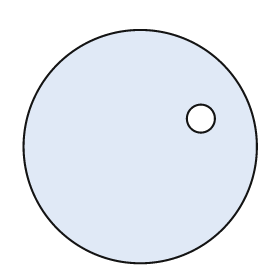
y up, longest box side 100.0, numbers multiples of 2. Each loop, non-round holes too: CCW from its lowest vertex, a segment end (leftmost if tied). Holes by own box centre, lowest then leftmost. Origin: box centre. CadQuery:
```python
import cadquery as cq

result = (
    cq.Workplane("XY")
    .moveTo(0.0, 0.0)
    .circle(50.0)
    .moveTo(26.0, 12.0)
    .circle(6.0)
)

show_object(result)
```